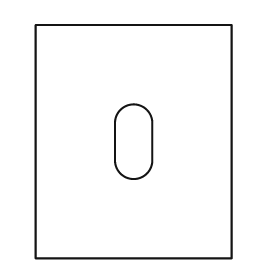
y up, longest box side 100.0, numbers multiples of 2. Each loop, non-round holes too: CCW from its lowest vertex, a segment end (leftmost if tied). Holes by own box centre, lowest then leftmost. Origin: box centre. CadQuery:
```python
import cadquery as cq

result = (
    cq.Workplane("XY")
    .moveTo(-42.0, -50.0)
    .lineTo(42.0, -50.0)
    .lineTo(42.0, 50.0)
    .lineTo(-42.0, 50.0)
    .close()
    .moveTo(-8.0, -8.0)
    .threePointArc((0.0, -16.0), (8.0, -8.0))
    .lineTo(8.0, 8.0)
    .threePointArc((0.0, 16.0), (-8.0, 8.0))
    .close()
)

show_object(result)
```